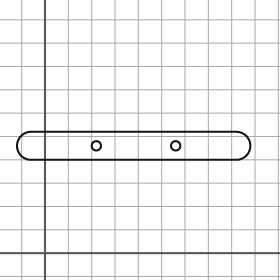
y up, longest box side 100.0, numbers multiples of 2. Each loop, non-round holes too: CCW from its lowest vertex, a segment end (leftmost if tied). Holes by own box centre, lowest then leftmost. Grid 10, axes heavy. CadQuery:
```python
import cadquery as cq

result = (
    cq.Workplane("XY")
    .moveTo(-6.0, 40.0)
    .lineTo(82.0, 40.0)
    .threePointArc((88.0, 46.0), (82.0, 52.0))
    .lineTo(-6.0, 52.0)
    .threePointArc((-12.0, 46.0), (-6.0, 40.0))
    .close()
    .moveTo(22.0, 46.0)
    .circle(2.0)
    .moveTo(56.0, 46.0)
    .circle(2.0)
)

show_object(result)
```